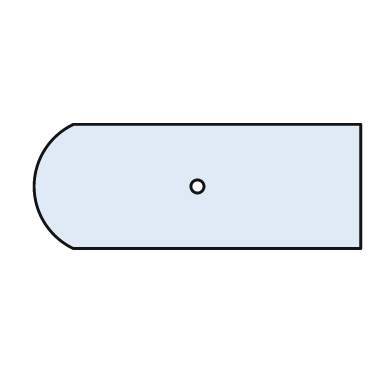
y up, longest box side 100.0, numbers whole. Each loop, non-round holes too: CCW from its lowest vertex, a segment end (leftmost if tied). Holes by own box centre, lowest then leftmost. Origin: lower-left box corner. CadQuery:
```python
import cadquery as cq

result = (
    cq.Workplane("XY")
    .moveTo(12.0, 0.0)
    .lineTo(100.0, 0.0)
    .lineTo(100.0, 38.0)
    .lineTo(12.0, 38.0)
    .threePointArc((0.0, 19.0), (12.0, 0.0))
    .close()
    .moveTo(50.0, 19.0)
    .circle(2.0)
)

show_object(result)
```